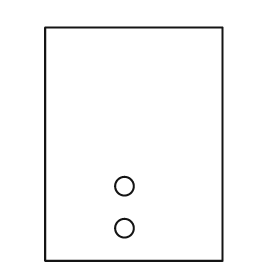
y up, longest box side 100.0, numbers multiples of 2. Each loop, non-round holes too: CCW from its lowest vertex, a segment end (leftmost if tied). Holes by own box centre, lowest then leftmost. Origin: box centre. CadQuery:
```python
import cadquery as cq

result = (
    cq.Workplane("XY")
    .moveTo(-38.0, -50.0)
    .lineTo(38.0, -50.0)
    .lineTo(38.0, 50.0)
    .lineTo(-38.0, 50.0)
    .close()
    .moveTo(-4.0, -36.0)
    .circle(4.0)
    .moveTo(-4.0, -18.0)
    .circle(4.0)
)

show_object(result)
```